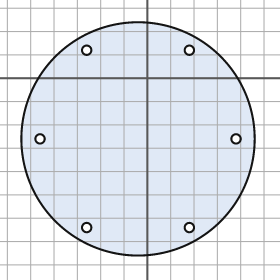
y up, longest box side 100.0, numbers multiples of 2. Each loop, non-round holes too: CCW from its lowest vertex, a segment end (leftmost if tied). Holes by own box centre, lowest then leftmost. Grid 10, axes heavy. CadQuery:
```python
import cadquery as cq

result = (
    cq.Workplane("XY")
    .moveTo(-4.0, -26.0)
    .circle(50.0)
    .moveTo(-26.0, -64.0)
    .circle(2.0)
    .moveTo(18.0, -64.0)
    .circle(2.0)
    .moveTo(-46.0, -26.0)
    .circle(2.0)
    .moveTo(38.0, -26.0)
    .circle(2.0)
    .moveTo(-26.0, 12.0)
    .circle(2.0)
    .moveTo(18.0, 12.0)
    .circle(2.0)
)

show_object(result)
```